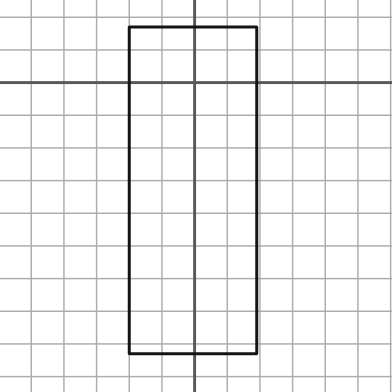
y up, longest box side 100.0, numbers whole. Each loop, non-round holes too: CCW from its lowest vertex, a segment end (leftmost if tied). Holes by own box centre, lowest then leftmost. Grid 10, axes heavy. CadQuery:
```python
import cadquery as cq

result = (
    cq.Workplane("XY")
    .moveTo(-20.0, -83.0)
    .lineTo(19.0, -83.0)
    .lineTo(19.0, 17.0)
    .lineTo(-20.0, 17.0)
    .close()
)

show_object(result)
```